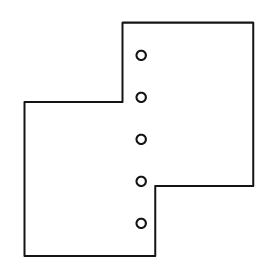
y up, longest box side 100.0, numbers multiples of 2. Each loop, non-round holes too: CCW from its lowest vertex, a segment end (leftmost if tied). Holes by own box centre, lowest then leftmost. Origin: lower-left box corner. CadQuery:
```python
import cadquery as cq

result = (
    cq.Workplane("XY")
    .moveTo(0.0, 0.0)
    .lineTo(56.0, 0.0)
    .lineTo(56.0, 30.0)
    .lineTo(98.0, 30.0)
    .lineTo(98.0, 100.0)
    .lineTo(42.0, 100.0)
    .lineTo(42.0, 66.0)
    .lineTo(0.0, 66.0)
    .close()
    .moveTo(50.0, 14.0)
    .circle(2.0)
    .moveTo(50.0, 32.0)
    .circle(2.0)
    .moveTo(50.0, 50.0)
    .circle(2.0)
    .moveTo(50.0, 68.0)
    .circle(2.0)
    .moveTo(50.0, 86.0)
    .circle(2.0)
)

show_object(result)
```